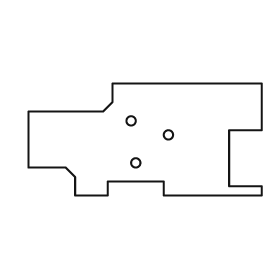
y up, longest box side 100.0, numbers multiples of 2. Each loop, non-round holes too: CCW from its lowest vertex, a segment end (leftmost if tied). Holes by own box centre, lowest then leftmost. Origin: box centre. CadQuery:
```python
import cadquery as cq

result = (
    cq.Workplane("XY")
    .moveTo(-30.0, -24.0)
    .lineTo(-16.0, -24.0)
    .lineTo(-16.0, -18.0)
    .lineTo(8.0, -18.0)
    .lineTo(8.0, -24.0)
    .lineTo(50.0, -24.0)
    .lineTo(50.0, -20.0)
    .lineTo(36.0, -20.0)
    .lineTo(36.0, 4.0)
    .lineTo(50.0, 4.0)
    .lineTo(50.0, 24.0)
    .lineTo(-14.0, 24.0)
    .lineTo(-14.0, 16.0)
    .lineTo(-18.0, 12.0)
    .lineTo(-50.0, 12.0)
    .lineTo(-50.0, -12.0)
    .lineTo(-34.0, -12.0)
    .lineTo(-30.0, -16.0)
    .close()
    .moveTo(-4.0, -10.0)
    .circle(2.0)
    .moveTo(10.0, 2.0)
    .circle(2.0)
    .moveTo(-6.0, 8.0)
    .circle(2.0)
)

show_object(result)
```